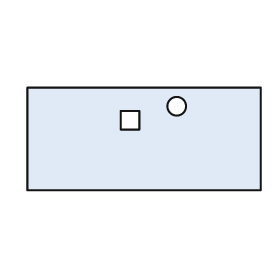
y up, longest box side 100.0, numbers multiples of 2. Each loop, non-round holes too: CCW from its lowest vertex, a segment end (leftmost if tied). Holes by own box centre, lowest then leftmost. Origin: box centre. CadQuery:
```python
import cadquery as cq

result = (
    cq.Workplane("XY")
    .moveTo(-50.0, -22.0)
    .lineTo(50.0, -22.0)
    .lineTo(50.0, 22.0)
    .lineTo(-50.0, 22.0)
    .close()
    .moveTo(-10.0, 4.0)
    .lineTo(-2.0, 4.0)
    .lineTo(-2.0, 12.0)
    .lineTo(-10.0, 12.0)
    .close()
    .moveTo(14.0, 14.0)
    .circle(4.0)
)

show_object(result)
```